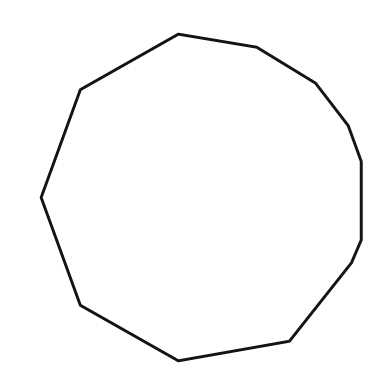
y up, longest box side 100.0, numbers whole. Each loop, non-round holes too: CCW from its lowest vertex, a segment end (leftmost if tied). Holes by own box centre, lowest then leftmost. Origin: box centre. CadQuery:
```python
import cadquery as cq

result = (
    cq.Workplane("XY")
    .moveTo(-7.0, -50.0)
    .lineTo(27.0, -44.0)
    .lineTo(46.0, -20.0)
    .lineTo(49.0, -13.0)
    .lineTo(49.0, 11.0)
    .lineTo(45.0, 22.0)
    .lineTo(35.0, 35.0)
    .lineTo(17.0, 46.0)
    .lineTo(-7.0, 50.0)
    .lineTo(-37.0, 33.0)
    .lineTo(-49.0, 0.0)
    .lineTo(-37.0, -33.0)
    .close()
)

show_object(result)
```